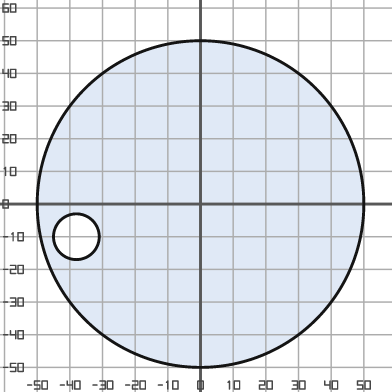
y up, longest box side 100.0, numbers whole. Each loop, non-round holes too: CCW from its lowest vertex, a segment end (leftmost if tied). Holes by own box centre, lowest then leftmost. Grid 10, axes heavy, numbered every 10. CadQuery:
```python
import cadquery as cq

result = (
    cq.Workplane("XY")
    .moveTo(0.0, 0.0)
    .circle(50.0)
    .moveTo(-38.0, -10.0)
    .circle(7.0)
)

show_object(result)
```